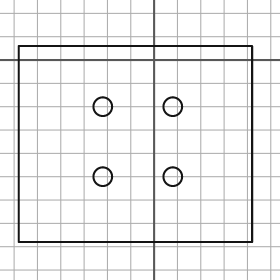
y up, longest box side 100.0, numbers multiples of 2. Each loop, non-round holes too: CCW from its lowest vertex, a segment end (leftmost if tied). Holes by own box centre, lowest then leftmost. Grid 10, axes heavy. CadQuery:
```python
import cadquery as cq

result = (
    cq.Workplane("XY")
    .moveTo(-58.0, -78.0)
    .lineTo(42.0, -78.0)
    .lineTo(42.0, 6.0)
    .lineTo(-58.0, 6.0)
    .close()
    .moveTo(-22.0, -50.0)
    .circle(4.0)
    .moveTo(8.0, -50.0)
    .circle(4.0)
    .moveTo(-22.0, -20.0)
    .circle(4.0)
    .moveTo(8.0, -20.0)
    .circle(4.0)
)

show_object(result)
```